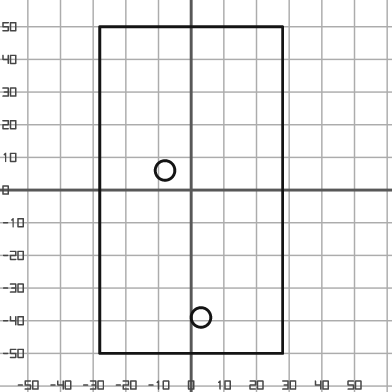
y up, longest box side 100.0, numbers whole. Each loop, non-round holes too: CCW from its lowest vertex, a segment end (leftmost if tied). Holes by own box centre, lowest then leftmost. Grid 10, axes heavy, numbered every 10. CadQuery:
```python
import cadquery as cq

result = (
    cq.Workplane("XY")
    .moveTo(-28.0, -50.0)
    .lineTo(28.0, -50.0)
    .lineTo(28.0, 50.0)
    .lineTo(-28.0, 50.0)
    .close()
    .moveTo(3.0, -39.0)
    .circle(3.0)
    .moveTo(-8.0, 6.0)
    .circle(3.0)
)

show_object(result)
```